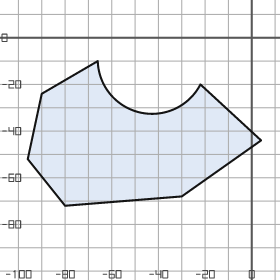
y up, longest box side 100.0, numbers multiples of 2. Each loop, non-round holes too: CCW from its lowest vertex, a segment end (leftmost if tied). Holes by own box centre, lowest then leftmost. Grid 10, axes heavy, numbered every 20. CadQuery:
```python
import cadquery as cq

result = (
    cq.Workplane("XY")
    .moveTo(-80.0, -72.0)
    .lineTo(-30.0, -68.0)
    .lineTo(4.0, -44.0)
    .lineTo(-22.0, -20.0)
    .threePointArc((-48.0, -32.0), (-66.0, -10.0))
    .lineTo(-90.0, -24.0)
    .lineTo(-96.0, -52.0)
    .close()
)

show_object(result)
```